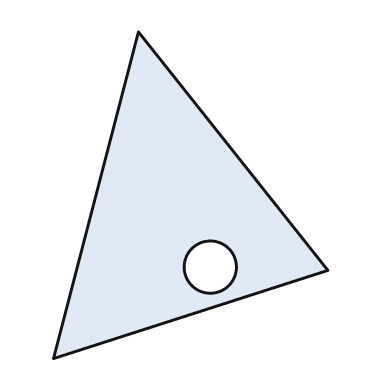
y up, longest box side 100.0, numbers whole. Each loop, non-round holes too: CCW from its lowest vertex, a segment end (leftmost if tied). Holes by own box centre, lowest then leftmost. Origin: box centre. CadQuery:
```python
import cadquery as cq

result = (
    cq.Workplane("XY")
    .moveTo(-42.0, -50.0)
    .lineTo(42.0, -23.0)
    .lineTo(-16.0, 50.0)
    .close()
    .moveTo(6.0, -22.0)
    .circle(8.0)
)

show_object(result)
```